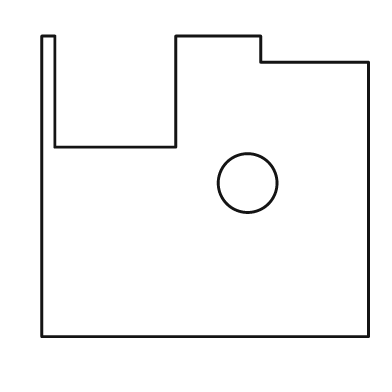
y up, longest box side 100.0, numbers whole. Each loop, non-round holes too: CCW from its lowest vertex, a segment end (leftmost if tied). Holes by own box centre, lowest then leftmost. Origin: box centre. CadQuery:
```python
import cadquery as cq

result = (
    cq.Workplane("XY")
    .moveTo(-50.0, -46.0)
    .lineTo(50.0, -46.0)
    .lineTo(50.0, 38.0)
    .lineTo(17.0, 38.0)
    .lineTo(17.0, 46.0)
    .lineTo(-9.0, 46.0)
    .lineTo(-9.0, 12.0)
    .lineTo(-46.0, 12.0)
    .lineTo(-46.0, 46.0)
    .lineTo(-50.0, 46.0)
    .close()
    .moveTo(13.0, 1.0)
    .circle(9.0)
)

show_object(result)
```